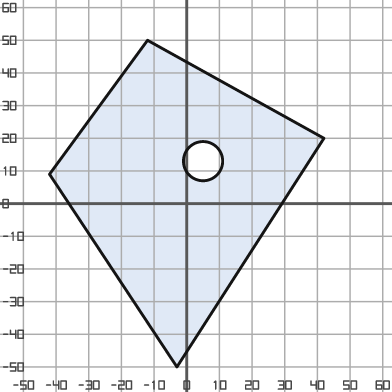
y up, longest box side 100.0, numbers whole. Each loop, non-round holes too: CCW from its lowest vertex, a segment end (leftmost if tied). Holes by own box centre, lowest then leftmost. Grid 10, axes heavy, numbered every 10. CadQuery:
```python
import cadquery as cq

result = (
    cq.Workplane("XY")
    .moveTo(-3.0, -50.0)
    .lineTo(42.0, 20.0)
    .lineTo(-12.0, 50.0)
    .lineTo(-42.0, 9.0)
    .close()
    .moveTo(5.0, 13.0)
    .circle(6.0)
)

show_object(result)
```